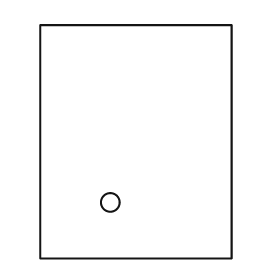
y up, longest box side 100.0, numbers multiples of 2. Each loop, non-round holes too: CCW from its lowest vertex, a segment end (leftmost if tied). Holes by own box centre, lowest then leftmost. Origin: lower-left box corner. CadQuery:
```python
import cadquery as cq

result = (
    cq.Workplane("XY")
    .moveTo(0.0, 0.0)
    .lineTo(82.0, 0.0)
    .lineTo(82.0, 100.0)
    .lineTo(0.0, 100.0)
    .close()
    .moveTo(30.0, 24.0)
    .circle(4.0)
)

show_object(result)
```